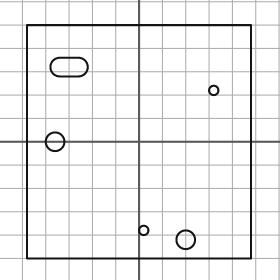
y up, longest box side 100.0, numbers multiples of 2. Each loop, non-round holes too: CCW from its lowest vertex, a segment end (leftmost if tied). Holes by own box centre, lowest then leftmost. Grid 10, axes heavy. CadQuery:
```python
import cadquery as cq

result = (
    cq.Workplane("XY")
    .moveTo(-48.0, -50.0)
    .lineTo(48.0, -50.0)
    .lineTo(48.0, 50.0)
    .lineTo(-48.0, 50.0)
    .close()
    .moveTo(20.0, -42.0)
    .circle(4.0)
    .moveTo(2.0, -38.0)
    .circle(2.0)
    .moveTo(-36.0, 0.0)
    .circle(4.0)
    .moveTo(32.0, 22.0)
    .circle(2.0)
    .moveTo(-34.0, 28.0)
    .lineTo(-26.0, 28.0)
    .threePointArc((-22.0, 32.0), (-26.0, 36.0))
    .lineTo(-34.0, 36.0)
    .threePointArc((-38.0, 32.0), (-34.0, 28.0))
    .close()
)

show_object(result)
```